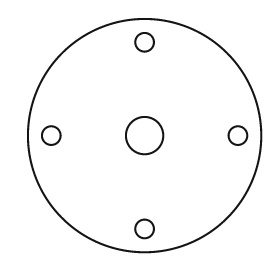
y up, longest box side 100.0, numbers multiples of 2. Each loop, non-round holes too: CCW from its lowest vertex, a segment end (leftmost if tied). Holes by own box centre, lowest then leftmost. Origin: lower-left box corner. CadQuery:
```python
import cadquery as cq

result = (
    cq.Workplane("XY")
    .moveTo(50.0, 50.0)
    .circle(50.0)
    .moveTo(50.0, 10.0)
    .circle(4.0)
    .moveTo(10.0, 50.0)
    .circle(4.0)
    .moveTo(50.0, 50.0)
    .circle(8.0)
    .moveTo(90.0, 50.0)
    .circle(4.0)
    .moveTo(50.0, 90.0)
    .circle(4.0)
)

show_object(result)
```